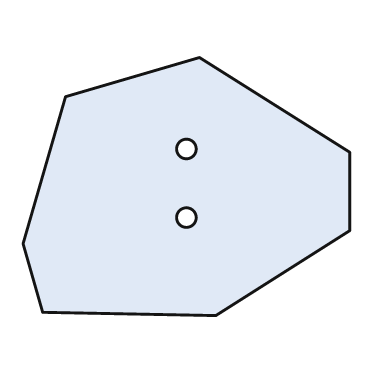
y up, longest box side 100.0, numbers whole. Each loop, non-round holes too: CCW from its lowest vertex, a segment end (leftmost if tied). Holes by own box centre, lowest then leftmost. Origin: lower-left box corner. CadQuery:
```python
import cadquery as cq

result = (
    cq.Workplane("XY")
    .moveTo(59.0, 0.0)
    .lineTo(100.0, 26.0)
    .lineTo(100.0, 50.0)
    .lineTo(54.0, 79.0)
    .lineTo(13.0, 67.0)
    .lineTo(0.0, 22.0)
    .lineTo(6.0, 1.0)
    .close()
    .moveTo(50.0, 30.0)
    .circle(3.0)
    .moveTo(50.0, 51.0)
    .circle(3.0)
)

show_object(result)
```